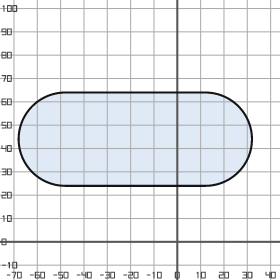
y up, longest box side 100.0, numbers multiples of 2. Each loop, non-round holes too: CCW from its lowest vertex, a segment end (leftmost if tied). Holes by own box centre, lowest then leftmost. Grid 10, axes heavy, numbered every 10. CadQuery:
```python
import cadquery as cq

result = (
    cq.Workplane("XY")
    .moveTo(-48.0, 24.0)
    .lineTo(12.0, 24.0)
    .threePointArc((32.0, 44.0), (12.0, 64.0))
    .lineTo(-48.0, 64.0)
    .threePointArc((-68.0, 44.0), (-48.0, 24.0))
    .close()
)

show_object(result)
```